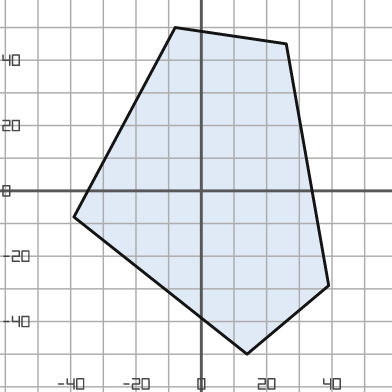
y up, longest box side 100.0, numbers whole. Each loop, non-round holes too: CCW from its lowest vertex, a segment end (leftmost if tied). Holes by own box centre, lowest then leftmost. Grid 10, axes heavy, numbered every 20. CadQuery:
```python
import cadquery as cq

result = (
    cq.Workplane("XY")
    .moveTo(14.0, -50.0)
    .lineTo(39.0, -29.0)
    .lineTo(26.0, 45.0)
    .lineTo(-8.0, 50.0)
    .lineTo(-39.0, -8.0)
    .close()
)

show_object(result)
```